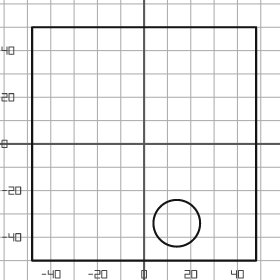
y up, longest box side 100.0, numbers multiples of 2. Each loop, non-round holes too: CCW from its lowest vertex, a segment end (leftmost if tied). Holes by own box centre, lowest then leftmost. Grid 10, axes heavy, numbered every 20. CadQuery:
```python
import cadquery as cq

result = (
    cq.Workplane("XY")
    .moveTo(-48.0, -50.0)
    .lineTo(48.0, -50.0)
    .lineTo(48.0, 50.0)
    .lineTo(-48.0, 50.0)
    .close()
    .moveTo(14.0, -34.0)
    .circle(10.0)
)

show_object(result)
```